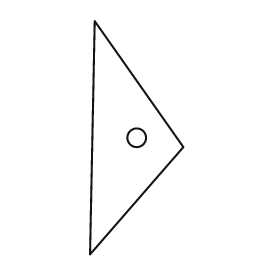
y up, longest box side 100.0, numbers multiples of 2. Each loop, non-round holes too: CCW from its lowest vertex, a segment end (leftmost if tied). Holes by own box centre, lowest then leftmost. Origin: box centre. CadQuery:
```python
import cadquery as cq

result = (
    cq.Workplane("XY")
    .moveTo(-20.0, -50.0)
    .lineTo(20.0, -4.0)
    .lineTo(-18.0, 50.0)
    .close()
    .moveTo(0.0, 0.0)
    .circle(4.0)
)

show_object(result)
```